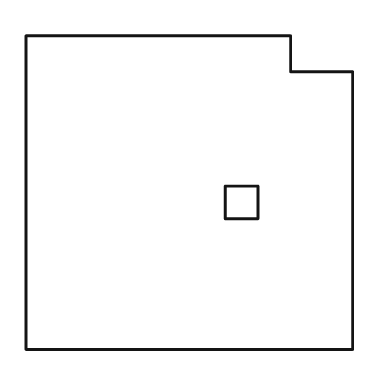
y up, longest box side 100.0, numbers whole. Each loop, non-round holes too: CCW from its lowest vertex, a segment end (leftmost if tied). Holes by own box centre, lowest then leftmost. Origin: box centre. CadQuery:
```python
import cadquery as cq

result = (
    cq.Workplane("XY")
    .moveTo(-50.0, -48.0)
    .lineTo(50.0, -48.0)
    .lineTo(50.0, 37.0)
    .lineTo(31.0, 37.0)
    .lineTo(31.0, 48.0)
    .lineTo(-50.0, 48.0)
    .close()
    .moveTo(11.0, -8.0)
    .lineTo(21.0, -8.0)
    .lineTo(21.0, 2.0)
    .lineTo(11.0, 2.0)
    .close()
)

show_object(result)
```